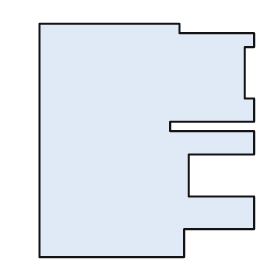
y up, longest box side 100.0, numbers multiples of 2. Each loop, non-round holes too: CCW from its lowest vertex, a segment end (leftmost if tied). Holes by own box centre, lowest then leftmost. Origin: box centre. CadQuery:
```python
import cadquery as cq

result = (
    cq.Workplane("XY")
    .moveTo(-46.0, -50.0)
    .lineTo(16.0, -50.0)
    .lineTo(16.0, -38.0)
    .lineTo(46.0, -38.0)
    .lineTo(46.0, -24.0)
    .lineTo(18.0, -24.0)
    .lineTo(18.0, -6.0)
    .lineTo(46.0, -6.0)
    .lineTo(46.0, 4.0)
    .lineTo(10.0, 4.0)
    .lineTo(10.0, 8.0)
    .lineTo(46.0, 8.0)
    .lineTo(46.0, 18.0)
    .lineTo(42.0, 18.0)
    .lineTo(42.0, 40.0)
    .lineTo(46.0, 40.0)
    .lineTo(46.0, 46.0)
    .lineTo(14.0, 46.0)
    .lineTo(14.0, 50.0)
    .lineTo(-46.0, 50.0)
    .close()
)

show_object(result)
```